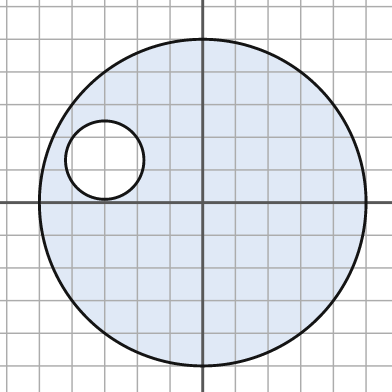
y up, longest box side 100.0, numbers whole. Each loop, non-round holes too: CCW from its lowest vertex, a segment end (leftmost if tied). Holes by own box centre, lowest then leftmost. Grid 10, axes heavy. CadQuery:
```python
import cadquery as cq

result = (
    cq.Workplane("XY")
    .moveTo(0.0, 0.0)
    .circle(50.0)
    .moveTo(-30.0, 13.0)
    .circle(12.0)
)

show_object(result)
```